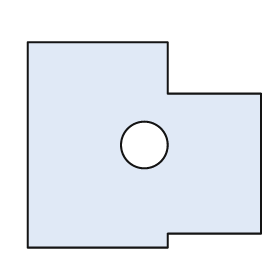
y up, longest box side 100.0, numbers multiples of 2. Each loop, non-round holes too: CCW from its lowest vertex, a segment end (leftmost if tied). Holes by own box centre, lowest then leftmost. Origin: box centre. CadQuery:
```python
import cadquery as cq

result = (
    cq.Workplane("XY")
    .moveTo(-50.0, -44.0)
    .lineTo(10.0, -44.0)
    .lineTo(10.0, -38.0)
    .lineTo(50.0, -38.0)
    .lineTo(50.0, 22.0)
    .lineTo(10.0, 22.0)
    .lineTo(10.0, 44.0)
    .lineTo(-50.0, 44.0)
    .close()
    .moveTo(0.0, 0.0)
    .circle(10.0)
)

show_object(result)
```